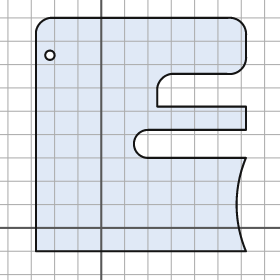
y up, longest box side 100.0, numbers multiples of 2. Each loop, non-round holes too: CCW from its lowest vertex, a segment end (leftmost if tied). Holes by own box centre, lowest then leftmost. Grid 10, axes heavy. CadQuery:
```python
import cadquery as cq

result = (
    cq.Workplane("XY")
    .moveTo(-28.0, -10.0)
    .lineTo(62.0, -10.0)
    .threePointArc((58.0, 10.0), (62.0, 30.0))
    .lineTo(20.0, 30.0)
    .threePointArc((14.0, 36.0), (20.0, 42.0))
    .lineTo(62.0, 42.0)
    .lineTo(62.0, 52.0)
    .lineTo(24.0, 52.0)
    .lineTo(24.0, 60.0)
    .threePointArc((26.0, 64.0), (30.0, 66.0))
    .lineTo(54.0, 66.0)
    .threePointArc((60.0, 68.0), (62.0, 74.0))
    .lineTo(62.0, 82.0)
    .threePointArc((60.0, 88.0), (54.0, 90.0))
    .lineTo(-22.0, 90.0)
    .threePointArc((-26.0, 88.0), (-28.0, 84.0))
    .close()
    .moveTo(-22.0, 74.0)
    .circle(2.0)
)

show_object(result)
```